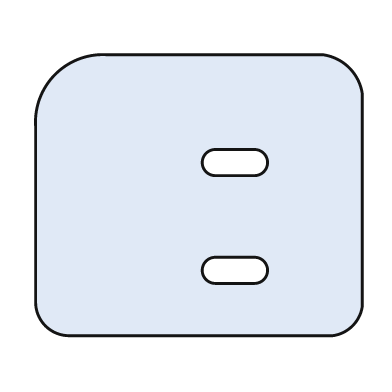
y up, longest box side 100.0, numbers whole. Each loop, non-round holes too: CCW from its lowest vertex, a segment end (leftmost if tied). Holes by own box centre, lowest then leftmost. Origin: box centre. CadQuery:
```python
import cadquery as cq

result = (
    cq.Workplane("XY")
    .moveTo(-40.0, -43.0)
    .lineTo(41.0, -43.0)
    .threePointArc((47.0, -40.0), (50.0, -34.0))
    .lineTo(50.0, 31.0)
    .threePointArc((46.0, 39.0), (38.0, 43.0))
    .lineTo(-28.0, 43.0)
    .threePointArc((-44.0, 37.0), (-50.0, 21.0))
    .lineTo(-50.0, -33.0)
    .threePointArc((-47.0, -40.0), (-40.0, -43.0))
    .close()
    .moveTo(5.0, -27.0)
    .lineTo(17.0, -27.0)
    .threePointArc((21.0, -23.0), (17.0, -19.0))
    .lineTo(5.0, -19.0)
    .threePointArc((1.0, -23.0), (5.0, -27.0))
    .close()
    .moveTo(5.0, 6.0)
    .lineTo(17.0, 6.0)
    .threePointArc((21.0, 10.0), (17.0, 14.0))
    .lineTo(5.0, 14.0)
    .threePointArc((1.0, 10.0), (5.0, 6.0))
    .close()
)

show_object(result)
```